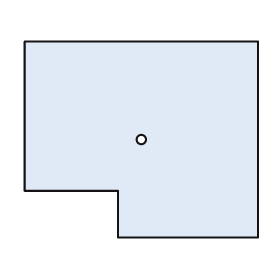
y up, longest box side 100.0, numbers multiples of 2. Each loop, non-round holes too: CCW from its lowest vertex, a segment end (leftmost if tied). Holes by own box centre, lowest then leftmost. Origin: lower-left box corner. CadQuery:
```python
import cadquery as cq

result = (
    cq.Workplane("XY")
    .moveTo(40.0, 0.0)
    .lineTo(100.0, 0.0)
    .lineTo(100.0, 84.0)
    .lineTo(0.0, 84.0)
    .lineTo(0.0, 20.0)
    .lineTo(40.0, 20.0)
    .close()
    .moveTo(50.0, 42.0)
    .circle(2.0)
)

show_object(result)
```